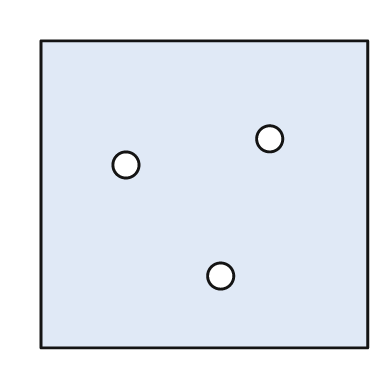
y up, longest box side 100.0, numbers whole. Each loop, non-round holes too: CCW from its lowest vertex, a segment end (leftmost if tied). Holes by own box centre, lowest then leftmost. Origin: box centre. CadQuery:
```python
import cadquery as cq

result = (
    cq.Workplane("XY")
    .moveTo(-50.0, -47.0)
    .lineTo(50.0, -47.0)
    .lineTo(50.0, 47.0)
    .lineTo(-50.0, 47.0)
    .close()
    .moveTo(5.0, -25.0)
    .circle(4.0)
    .moveTo(-24.0, 9.0)
    .circle(4.0)
    .moveTo(20.0, 17.0)
    .circle(4.0)
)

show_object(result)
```